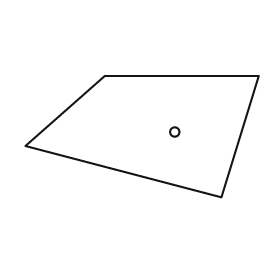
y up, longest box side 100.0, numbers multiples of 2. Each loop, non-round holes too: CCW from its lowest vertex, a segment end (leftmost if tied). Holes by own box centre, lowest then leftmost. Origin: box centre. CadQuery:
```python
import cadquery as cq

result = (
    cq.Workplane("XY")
    .moveTo(34.0, -26.0)
    .lineTo(50.0, 26.0)
    .lineTo(-16.0, 26.0)
    .lineTo(-50.0, -4.0)
    .close()
    .moveTo(14.0, 2.0)
    .circle(2.0)
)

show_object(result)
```